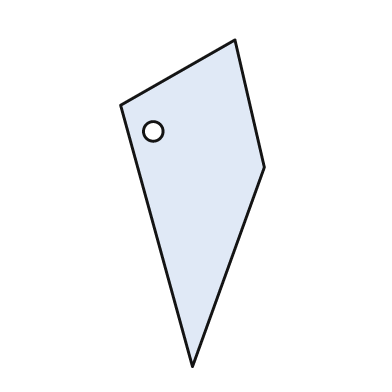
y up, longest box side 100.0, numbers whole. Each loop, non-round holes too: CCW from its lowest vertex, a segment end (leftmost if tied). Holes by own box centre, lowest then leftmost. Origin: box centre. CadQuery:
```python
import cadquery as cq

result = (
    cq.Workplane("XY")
    .moveTo(0.0, -50.0)
    .lineTo(22.0, 11.0)
    .lineTo(13.0, 50.0)
    .lineTo(-22.0, 30.0)
    .close()
    .moveTo(-12.0, 22.0)
    .circle(3.0)
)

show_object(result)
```